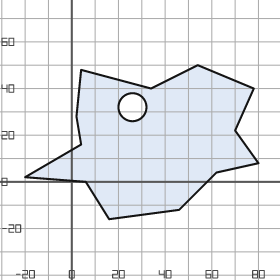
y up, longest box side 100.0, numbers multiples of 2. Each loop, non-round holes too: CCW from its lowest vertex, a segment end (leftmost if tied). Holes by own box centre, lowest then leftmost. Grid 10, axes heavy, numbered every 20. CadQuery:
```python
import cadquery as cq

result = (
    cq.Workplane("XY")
    .moveTo(16.0, -16.0)
    .lineTo(46.0, -12.0)
    .lineTo(62.0, 4.0)
    .lineTo(80.0, 8.0)
    .lineTo(70.0, 22.0)
    .lineTo(78.0, 40.0)
    .lineTo(54.0, 50.0)
    .lineTo(34.0, 40.0)
    .lineTo(4.0, 48.0)
    .lineTo(2.0, 28.0)
    .lineTo(4.0, 16.0)
    .lineTo(-20.0, 2.0)
    .lineTo(6.0, 0.0)
    .close()
    .moveTo(26.0, 32.0)
    .circle(6.0)
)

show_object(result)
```